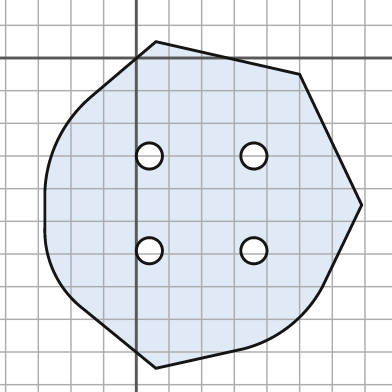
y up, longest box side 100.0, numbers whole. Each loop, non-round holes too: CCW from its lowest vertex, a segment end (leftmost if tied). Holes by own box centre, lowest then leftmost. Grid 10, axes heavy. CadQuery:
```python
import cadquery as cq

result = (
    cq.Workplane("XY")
    .moveTo(6.0, -95.0)
    .lineTo(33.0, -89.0)
    .threePointArc((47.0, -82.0), (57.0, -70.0))
    .lineTo(69.0, -45.0)
    .lineTo(50.0, -5.0)
    .lineTo(6.0, 5.0)
    .lineTo(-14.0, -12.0)
    .threePointArc((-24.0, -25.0), (-28.0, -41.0))
    .lineTo(-28.0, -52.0)
    .threePointArc((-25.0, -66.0), (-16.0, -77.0))
    .close()
    .moveTo(4.0, -59.0)
    .circle(4.0)
    .moveTo(36.0, -59.0)
    .circle(4.0)
    .moveTo(4.0, -30.0)
    .circle(4.0)
    .moveTo(36.0, -30.0)
    .circle(4.0)
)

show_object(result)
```